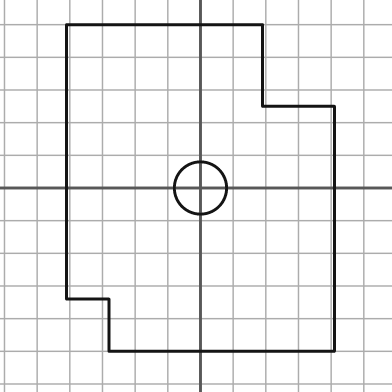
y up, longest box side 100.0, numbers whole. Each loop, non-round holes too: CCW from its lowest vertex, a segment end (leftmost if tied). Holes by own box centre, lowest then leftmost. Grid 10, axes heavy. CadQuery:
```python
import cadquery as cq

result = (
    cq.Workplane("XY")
    .moveTo(-28.0, -50.0)
    .lineTo(41.0, -50.0)
    .lineTo(41.0, 25.0)
    .lineTo(19.0, 25.0)
    .lineTo(19.0, 50.0)
    .lineTo(-41.0, 50.0)
    .lineTo(-41.0, -34.0)
    .lineTo(-28.0, -34.0)
    .close()
    .moveTo(0.0, 0.0)
    .circle(8.0)
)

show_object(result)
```